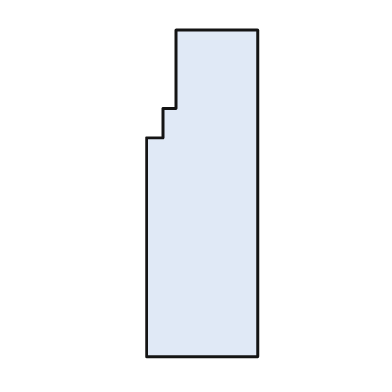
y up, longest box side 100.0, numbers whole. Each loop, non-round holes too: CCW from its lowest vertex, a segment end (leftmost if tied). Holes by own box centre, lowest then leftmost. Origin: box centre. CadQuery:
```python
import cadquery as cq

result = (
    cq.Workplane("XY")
    .moveTo(-17.0, -50.0)
    .lineTo(17.0, -50.0)
    .lineTo(17.0, 50.0)
    .lineTo(-8.0, 50.0)
    .lineTo(-8.0, 26.0)
    .lineTo(-12.0, 26.0)
    .lineTo(-12.0, 17.0)
    .lineTo(-17.0, 17.0)
    .close()
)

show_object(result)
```